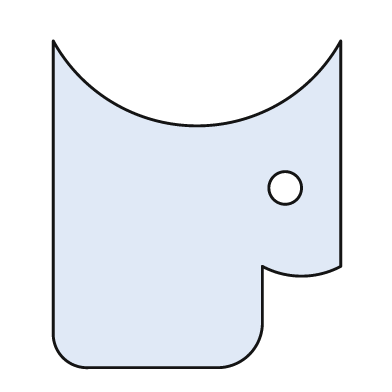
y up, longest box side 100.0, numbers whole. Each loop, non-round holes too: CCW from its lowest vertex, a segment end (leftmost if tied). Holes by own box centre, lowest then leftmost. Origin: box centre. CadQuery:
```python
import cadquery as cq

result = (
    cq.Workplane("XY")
    .moveTo(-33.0, -50.0)
    .lineTo(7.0, -50.0)
    .threePointArc((16.0, -46.0), (20.0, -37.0))
    .lineTo(20.0, -19.0)
    .threePointArc((32.0, -22.0), (44.0, -19.0))
    .lineTo(44.0, 50.0)
    .threePointArc((0.0, 24.0), (-44.0, 50.0))
    .lineTo(-44.0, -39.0)
    .threePointArc((-41.0, -47.0), (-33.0, -50.0))
    .close()
    .moveTo(27.0, 5.0)
    .circle(5.0)
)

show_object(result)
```